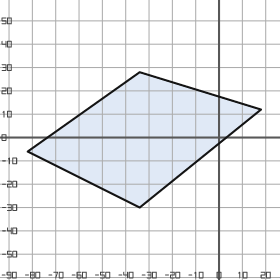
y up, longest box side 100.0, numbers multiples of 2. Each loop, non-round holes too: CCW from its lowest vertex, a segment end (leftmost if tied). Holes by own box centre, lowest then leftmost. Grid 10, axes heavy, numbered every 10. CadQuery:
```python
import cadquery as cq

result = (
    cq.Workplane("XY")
    .moveTo(-34.0, -30.0)
    .lineTo(18.0, 12.0)
    .lineTo(-34.0, 28.0)
    .lineTo(-82.0, -6.0)
    .close()
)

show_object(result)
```